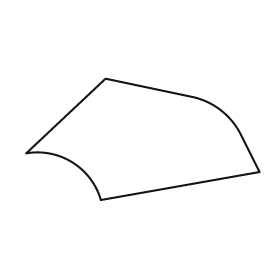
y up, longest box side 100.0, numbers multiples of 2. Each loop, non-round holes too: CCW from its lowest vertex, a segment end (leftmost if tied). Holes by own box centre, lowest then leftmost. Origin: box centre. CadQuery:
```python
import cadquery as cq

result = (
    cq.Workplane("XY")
    .moveTo(-18.0, -26.0)
    .lineTo(50.0, -14.0)
    .lineTo(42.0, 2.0)
    .threePointArc((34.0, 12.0), (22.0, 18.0))
    .lineTo(-16.0, 26.0)
    .lineTo(-50.0, -6.0)
    .threePointArc((-30.0, -10.0), (-18.0, -26.0))
    .close()
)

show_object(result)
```